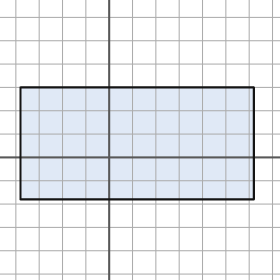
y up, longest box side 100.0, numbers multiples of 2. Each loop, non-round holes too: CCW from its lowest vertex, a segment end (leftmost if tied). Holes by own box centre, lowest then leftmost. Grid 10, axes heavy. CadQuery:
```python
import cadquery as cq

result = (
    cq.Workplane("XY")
    .moveTo(-38.0, -18.0)
    .lineTo(62.0, -18.0)
    .lineTo(62.0, 30.0)
    .lineTo(-38.0, 30.0)
    .close()
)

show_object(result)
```